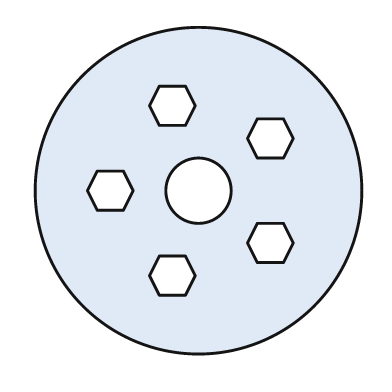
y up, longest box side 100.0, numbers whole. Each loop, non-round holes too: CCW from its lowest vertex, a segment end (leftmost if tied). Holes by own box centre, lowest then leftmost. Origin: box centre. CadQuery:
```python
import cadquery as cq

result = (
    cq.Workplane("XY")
    .moveTo(0.0, 0.0)
    .circle(50.0)
    .moveTo(-12.0, -32.0)
    .lineTo(-4.0, -32.0)
    .lineTo(-1.0, -26.0)
    .lineTo(-4.0, -20.0)
    .lineTo(-12.0, -20.0)
    .lineTo(-15.0, -26.0)
    .close()
    .moveTo(18.0, -22.0)
    .lineTo(26.0, -22.0)
    .lineTo(29.0, -16.0)
    .lineTo(26.0, -10.0)
    .lineTo(18.0, -10.0)
    .lineTo(15.0, -16.0)
    .close()
    .moveTo(-31.0, -6.0)
    .lineTo(-23.0, -6.0)
    .lineTo(-20.0, 0.0)
    .lineTo(-23.0, 6.0)
    .lineTo(-31.0, 6.0)
    .lineTo(-34.0, 0.0)
    .close()
    .moveTo(0.0, 0.0)
    .circle(10.0)
    .moveTo(18.0, 10.0)
    .lineTo(26.0, 10.0)
    .lineTo(29.0, 16.0)
    .lineTo(26.0, 22.0)
    .lineTo(18.0, 22.0)
    .lineTo(15.0, 16.0)
    .close()
    .moveTo(-12.0, 20.0)
    .lineTo(-4.0, 20.0)
    .lineTo(-1.0, 26.0)
    .lineTo(-4.0, 32.0)
    .lineTo(-12.0, 32.0)
    .lineTo(-15.0, 26.0)
    .close()
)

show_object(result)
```